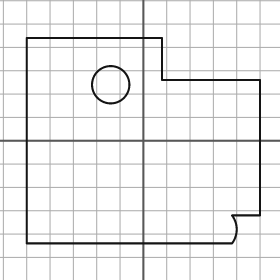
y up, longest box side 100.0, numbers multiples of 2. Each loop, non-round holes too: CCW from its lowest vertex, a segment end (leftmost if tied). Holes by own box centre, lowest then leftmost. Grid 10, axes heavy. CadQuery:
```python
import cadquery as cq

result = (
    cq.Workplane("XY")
    .moveTo(-50.0, -44.0)
    .lineTo(38.0, -44.0)
    .threePointArc((40.0, -38.0), (38.0, -32.0))
    .lineTo(50.0, -32.0)
    .lineTo(50.0, 26.0)
    .lineTo(8.0, 26.0)
    .lineTo(8.0, 44.0)
    .lineTo(-50.0, 44.0)
    .close()
    .moveTo(-14.0, 24.0)
    .circle(8.0)
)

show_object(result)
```